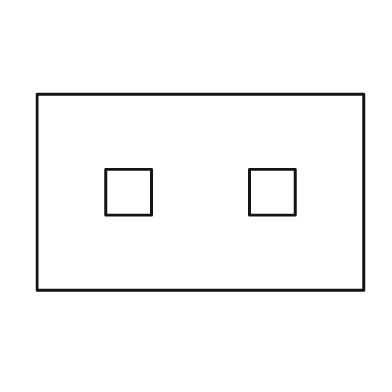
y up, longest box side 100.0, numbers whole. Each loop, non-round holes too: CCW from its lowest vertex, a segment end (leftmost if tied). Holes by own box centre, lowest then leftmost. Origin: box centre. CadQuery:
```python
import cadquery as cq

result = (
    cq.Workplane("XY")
    .moveTo(-50.0, -30.0)
    .lineTo(50.0, -30.0)
    .lineTo(50.0, 30.0)
    .lineTo(-50.0, 30.0)
    .close()
    .moveTo(-29.0, -7.0)
    .lineTo(-15.0, -7.0)
    .lineTo(-15.0, 7.0)
    .lineTo(-29.0, 7.0)
    .close()
    .moveTo(15.0, -7.0)
    .lineTo(29.0, -7.0)
    .lineTo(29.0, 7.0)
    .lineTo(15.0, 7.0)
    .close()
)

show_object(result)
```